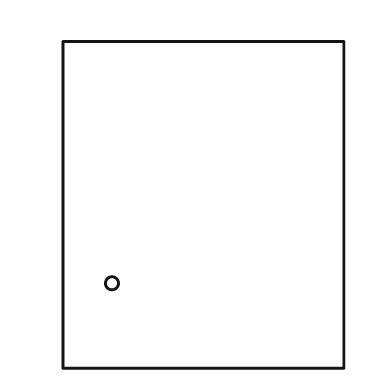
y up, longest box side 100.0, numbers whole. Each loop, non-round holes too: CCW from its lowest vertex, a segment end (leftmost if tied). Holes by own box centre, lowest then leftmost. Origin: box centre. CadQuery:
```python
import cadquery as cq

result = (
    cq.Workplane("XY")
    .moveTo(-43.0, -50.0)
    .lineTo(43.0, -50.0)
    .lineTo(43.0, 50.0)
    .lineTo(-43.0, 50.0)
    .close()
    .moveTo(-28.0, -24.0)
    .circle(2.0)
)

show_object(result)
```